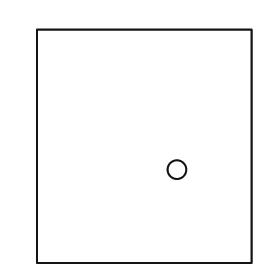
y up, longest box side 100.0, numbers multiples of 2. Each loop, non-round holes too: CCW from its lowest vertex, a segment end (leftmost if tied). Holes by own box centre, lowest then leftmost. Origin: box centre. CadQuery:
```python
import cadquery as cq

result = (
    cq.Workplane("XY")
    .moveTo(-46.0, -50.0)
    .lineTo(46.0, -50.0)
    .lineTo(46.0, 50.0)
    .lineTo(-46.0, 50.0)
    .close()
    .moveTo(14.0, -10.0)
    .circle(4.0)
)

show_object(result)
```